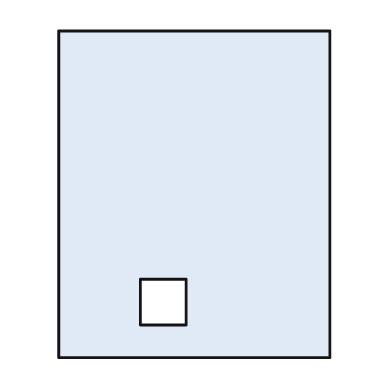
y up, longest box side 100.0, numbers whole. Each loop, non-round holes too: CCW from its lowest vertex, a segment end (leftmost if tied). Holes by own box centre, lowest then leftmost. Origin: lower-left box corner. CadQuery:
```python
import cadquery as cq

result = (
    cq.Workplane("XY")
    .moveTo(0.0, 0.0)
    .lineTo(83.0, 0.0)
    .lineTo(83.0, 100.0)
    .lineTo(0.0, 100.0)
    .close()
    .moveTo(25.0, 10.0)
    .lineTo(39.0, 10.0)
    .lineTo(39.0, 24.0)
    .lineTo(25.0, 24.0)
    .close()
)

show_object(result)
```